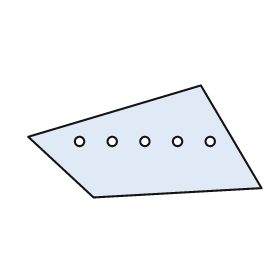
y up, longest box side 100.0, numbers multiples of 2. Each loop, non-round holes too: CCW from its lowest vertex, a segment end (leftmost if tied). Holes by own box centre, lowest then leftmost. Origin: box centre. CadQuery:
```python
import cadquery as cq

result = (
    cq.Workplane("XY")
    .moveTo(-22.0, -24.0)
    .lineTo(50.0, -20.0)
    .lineTo(24.0, 24.0)
    .lineTo(-50.0, 2.0)
    .close()
    .moveTo(-28.0, 0.0)
    .circle(2.0)
    .moveTo(-14.0, 0.0)
    .circle(2.0)
    .moveTo(0.0, 0.0)
    .circle(2.0)
    .moveTo(14.0, 0.0)
    .circle(2.0)
    .moveTo(28.0, 0.0)
    .circle(2.0)
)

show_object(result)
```